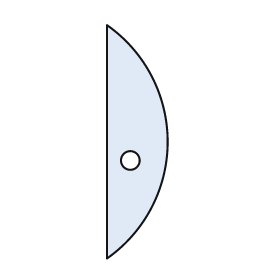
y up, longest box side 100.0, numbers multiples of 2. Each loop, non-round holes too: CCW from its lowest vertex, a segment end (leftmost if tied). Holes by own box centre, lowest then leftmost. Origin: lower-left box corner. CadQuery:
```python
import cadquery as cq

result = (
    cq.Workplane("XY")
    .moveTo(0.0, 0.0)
    .threePointArc((26.0, 50.0), (0.0, 100.0))
    .close()
    .moveTo(10.0, 42.0)
    .circle(4.0)
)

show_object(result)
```